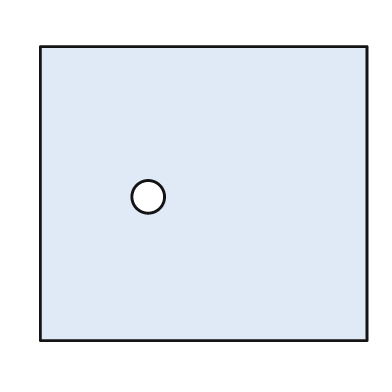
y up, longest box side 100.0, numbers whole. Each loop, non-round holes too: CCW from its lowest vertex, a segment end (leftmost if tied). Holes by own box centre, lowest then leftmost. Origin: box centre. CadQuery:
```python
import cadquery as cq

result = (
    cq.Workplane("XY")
    .moveTo(-50.0, -45.0)
    .lineTo(50.0, -45.0)
    .lineTo(50.0, 45.0)
    .lineTo(-50.0, 45.0)
    .close()
    .moveTo(-17.0, -1.0)
    .circle(5.0)
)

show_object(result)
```